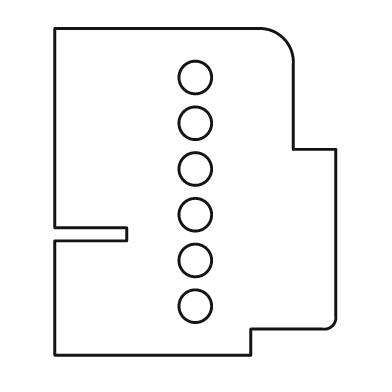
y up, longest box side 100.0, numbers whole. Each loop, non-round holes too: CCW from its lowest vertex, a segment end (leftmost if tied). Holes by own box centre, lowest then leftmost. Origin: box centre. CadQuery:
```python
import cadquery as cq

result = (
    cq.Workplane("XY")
    .moveTo(-43.0, -50.0)
    .lineTo(17.0, -50.0)
    .lineTo(17.0, -42.0)
    .lineTo(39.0, -42.0)
    .threePointArc((42.0, -41.0), (43.0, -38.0))
    .lineTo(43.0, 13.0)
    .lineTo(30.0, 13.0)
    .lineTo(30.0, 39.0)
    .threePointArc((27.0, 47.0), (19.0, 50.0))
    .lineTo(-43.0, 50.0)
    .lineTo(-43.0, -11.0)
    .lineTo(-21.0, -11.0)
    .lineTo(-21.0, -15.0)
    .lineTo(-43.0, -15.0)
    .close()
    .moveTo(0.0, -35.0)
    .circle(5.0)
    .moveTo(0.0, -21.0)
    .circle(5.0)
    .moveTo(0.0, -7.0)
    .circle(5.0)
    .moveTo(0.0, 7.0)
    .circle(5.0)
    .moveTo(0.0, 21.0)
    .circle(5.0)
    .moveTo(0.0, 35.0)
    .circle(5.0)
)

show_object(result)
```